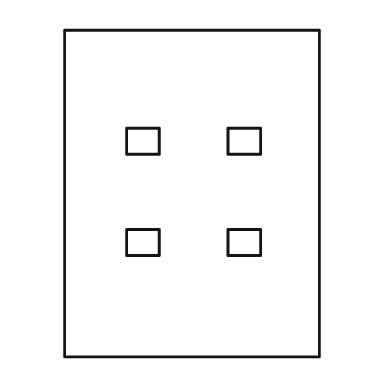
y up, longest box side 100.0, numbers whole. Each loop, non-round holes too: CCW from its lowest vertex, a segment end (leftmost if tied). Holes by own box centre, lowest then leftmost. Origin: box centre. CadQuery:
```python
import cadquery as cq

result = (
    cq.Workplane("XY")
    .moveTo(-39.0, -50.0)
    .lineTo(39.0, -50.0)
    .lineTo(39.0, 50.0)
    .lineTo(-39.0, 50.0)
    .close()
    .moveTo(-20.0, -19.0)
    .lineTo(-10.0, -19.0)
    .lineTo(-10.0, -11.0)
    .lineTo(-20.0, -11.0)
    .close()
    .moveTo(11.0, -19.0)
    .lineTo(21.0, -19.0)
    .lineTo(21.0, -11.0)
    .lineTo(11.0, -11.0)
    .close()
    .moveTo(-20.0, 12.0)
    .lineTo(-10.0, 12.0)
    .lineTo(-10.0, 20.0)
    .lineTo(-20.0, 20.0)
    .close()
    .moveTo(11.0, 12.0)
    .lineTo(21.0, 12.0)
    .lineTo(21.0, 20.0)
    .lineTo(11.0, 20.0)
    .close()
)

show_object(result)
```